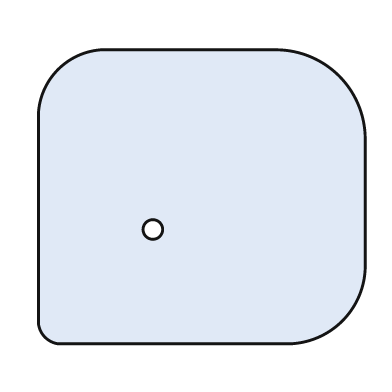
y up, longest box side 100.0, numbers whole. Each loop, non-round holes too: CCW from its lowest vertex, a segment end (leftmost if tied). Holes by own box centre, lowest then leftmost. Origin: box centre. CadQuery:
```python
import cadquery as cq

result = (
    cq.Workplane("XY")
    .moveTo(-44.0, -45.0)
    .lineTo(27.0, -45.0)
    .threePointArc((43.0, -38.0), (50.0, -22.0))
    .lineTo(50.0, 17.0)
    .threePointArc((42.0, 37.0), (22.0, 45.0))
    .lineTo(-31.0, 45.0)
    .threePointArc((-44.0, 39.0), (-50.0, 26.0))
    .lineTo(-50.0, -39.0)
    .threePointArc((-48.0, -43.0), (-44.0, -45.0))
    .close()
    .moveTo(-15.0, -10.0)
    .circle(3.0)
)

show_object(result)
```